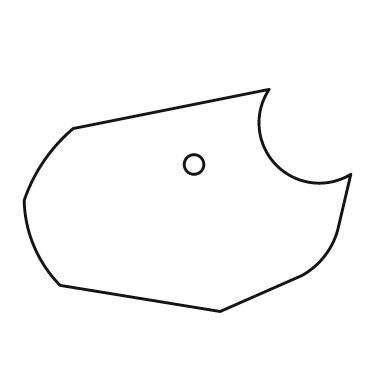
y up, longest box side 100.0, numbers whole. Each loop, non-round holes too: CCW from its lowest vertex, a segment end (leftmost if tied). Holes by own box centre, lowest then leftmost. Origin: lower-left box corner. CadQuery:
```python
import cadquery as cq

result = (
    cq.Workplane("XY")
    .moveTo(60.0, 0.0)
    .lineTo(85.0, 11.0)
    .threePointArc((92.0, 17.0), (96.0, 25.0))
    .lineTo(100.0, 42.0)
    .threePointArc((77.0, 45.0), (75.0, 68.0))
    .lineTo(15.0, 56.0)
    .threePointArc((6.0, 46.0), (0.0, 34.0))
    .threePointArc((3.0, 20.0), (11.0, 8.0))
    .close()
    .moveTo(52.0, 45.0)
    .circle(3.0)
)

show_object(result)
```